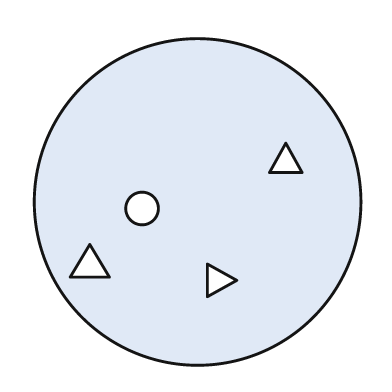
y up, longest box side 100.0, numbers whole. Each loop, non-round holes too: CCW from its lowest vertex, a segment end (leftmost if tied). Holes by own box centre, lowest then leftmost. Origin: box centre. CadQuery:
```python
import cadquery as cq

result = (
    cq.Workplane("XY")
    .moveTo(0.0, 0.0)
    .circle(50.0)
    .moveTo(3.0, -29.0)
    .lineTo(12.0, -24.0)
    .lineTo(3.0, -19.0)
    .close()
    .moveTo(-39.0, -23.0)
    .lineTo(-27.0, -23.0)
    .lineTo(-33.0, -13.0)
    .close()
    .moveTo(-17.0, -2.0)
    .circle(5.0)
    .moveTo(22.0, 9.0)
    .lineTo(32.0, 9.0)
    .lineTo(27.0, 18.0)
    .close()
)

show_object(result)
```